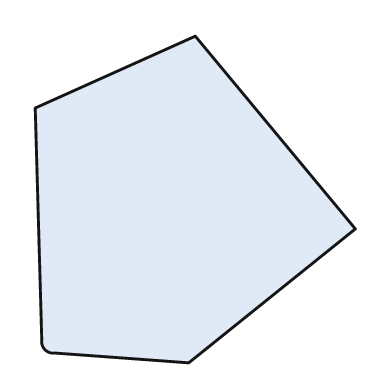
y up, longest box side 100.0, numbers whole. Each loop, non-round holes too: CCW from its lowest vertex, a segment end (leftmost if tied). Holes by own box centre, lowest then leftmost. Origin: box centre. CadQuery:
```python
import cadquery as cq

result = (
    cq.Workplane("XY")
    .moveTo(-2.0, -50.0)
    .lineTo(49.0, -9.0)
    .lineTo(0.0, 50.0)
    .lineTo(-49.0, 28.0)
    .lineTo(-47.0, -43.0)
    .threePointArc((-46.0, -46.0), (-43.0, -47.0))
    .close()
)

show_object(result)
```